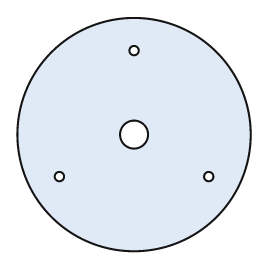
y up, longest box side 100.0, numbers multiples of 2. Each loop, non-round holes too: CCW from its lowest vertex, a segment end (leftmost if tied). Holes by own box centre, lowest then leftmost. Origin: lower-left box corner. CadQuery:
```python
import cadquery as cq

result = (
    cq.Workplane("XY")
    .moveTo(50.0, 50.0)
    .circle(50.0)
    .moveTo(18.0, 32.0)
    .circle(2.0)
    .moveTo(82.0, 32.0)
    .circle(2.0)
    .moveTo(50.0, 50.0)
    .circle(6.0)
    .moveTo(50.0, 86.0)
    .circle(2.0)
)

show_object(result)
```